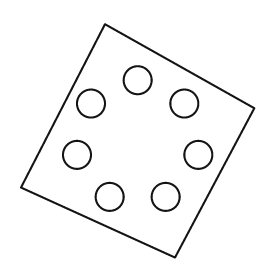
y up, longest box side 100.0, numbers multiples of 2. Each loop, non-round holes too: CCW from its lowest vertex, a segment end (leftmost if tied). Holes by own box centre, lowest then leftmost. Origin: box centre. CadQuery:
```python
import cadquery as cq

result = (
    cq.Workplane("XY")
    .moveTo(16.0, -50.0)
    .lineTo(50.0, 14.0)
    .lineTo(-14.0, 50.0)
    .lineTo(-50.0, -20.0)
    .close()
    .moveTo(-12.0, -24.0)
    .circle(6.0)
    .moveTo(12.0, -24.0)
    .circle(6.0)
    .moveTo(-26.0, -6.0)
    .circle(6.0)
    .moveTo(26.0, -6.0)
    .circle(6.0)
    .moveTo(-20.0, 16.0)
    .circle(6.0)
    .moveTo(20.0, 16.0)
    .circle(6.0)
    .moveTo(0.0, 26.0)
    .circle(6.0)
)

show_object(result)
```